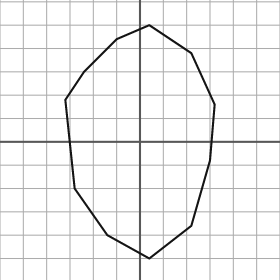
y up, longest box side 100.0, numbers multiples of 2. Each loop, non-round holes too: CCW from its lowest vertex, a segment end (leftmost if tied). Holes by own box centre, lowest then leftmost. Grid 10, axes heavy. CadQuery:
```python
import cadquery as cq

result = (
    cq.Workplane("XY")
    .moveTo(4.0, -50.0)
    .lineTo(22.0, -36.0)
    .lineTo(30.0, -8.0)
    .lineTo(32.0, 16.0)
    .lineTo(22.0, 38.0)
    .lineTo(4.0, 50.0)
    .lineTo(-10.0, 44.0)
    .lineTo(-24.0, 30.0)
    .lineTo(-32.0, 18.0)
    .lineTo(-28.0, -20.0)
    .lineTo(-14.0, -40.0)
    .close()
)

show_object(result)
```